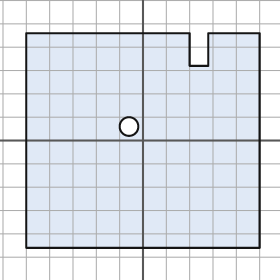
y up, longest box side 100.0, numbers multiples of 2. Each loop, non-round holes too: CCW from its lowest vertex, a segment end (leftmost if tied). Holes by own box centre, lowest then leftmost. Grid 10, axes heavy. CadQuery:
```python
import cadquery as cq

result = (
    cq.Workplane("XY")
    .moveTo(-50.0, -46.0)
    .lineTo(50.0, -46.0)
    .lineTo(50.0, 46.0)
    .lineTo(28.0, 46.0)
    .lineTo(28.0, 32.0)
    .lineTo(20.0, 32.0)
    .lineTo(20.0, 46.0)
    .lineTo(-50.0, 46.0)
    .close()
    .moveTo(-6.0, 6.0)
    .circle(4.0)
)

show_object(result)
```